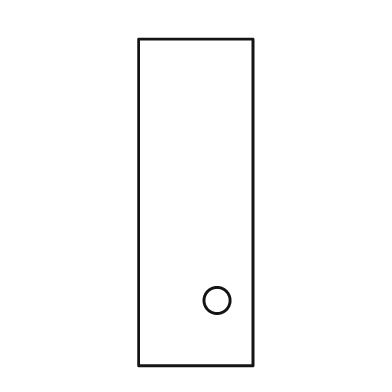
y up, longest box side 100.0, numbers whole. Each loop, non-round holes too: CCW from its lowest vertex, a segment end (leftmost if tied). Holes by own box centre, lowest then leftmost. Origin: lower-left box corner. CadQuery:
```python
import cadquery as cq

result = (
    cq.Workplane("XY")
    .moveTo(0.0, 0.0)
    .lineTo(35.0, 0.0)
    .lineTo(35.0, 100.0)
    .lineTo(0.0, 100.0)
    .close()
    .moveTo(24.0, 20.0)
    .circle(4.0)
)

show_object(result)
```